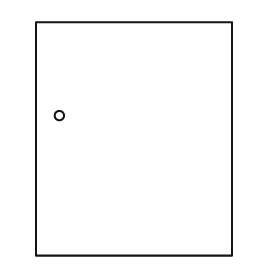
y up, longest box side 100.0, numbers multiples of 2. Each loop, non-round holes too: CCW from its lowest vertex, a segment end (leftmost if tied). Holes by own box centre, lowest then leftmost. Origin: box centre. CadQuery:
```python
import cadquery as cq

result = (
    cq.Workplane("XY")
    .moveTo(-42.0, -50.0)
    .lineTo(42.0, -50.0)
    .lineTo(42.0, 50.0)
    .lineTo(-42.0, 50.0)
    .close()
    .moveTo(-32.0, 10.0)
    .circle(2.0)
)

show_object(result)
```